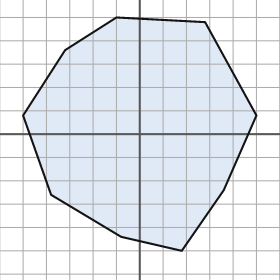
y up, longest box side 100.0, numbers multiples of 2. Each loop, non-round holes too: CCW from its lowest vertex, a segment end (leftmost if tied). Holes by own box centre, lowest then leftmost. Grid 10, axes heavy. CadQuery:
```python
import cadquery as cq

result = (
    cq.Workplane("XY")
    .moveTo(18.0, -50.0)
    .lineTo(36.0, -24.0)
    .lineTo(50.0, 8.0)
    .lineTo(28.0, 48.0)
    .lineTo(-10.0, 50.0)
    .lineTo(-32.0, 36.0)
    .lineTo(-50.0, 8.0)
    .lineTo(-38.0, -26.0)
    .lineTo(-8.0, -44.0)
    .close()
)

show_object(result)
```